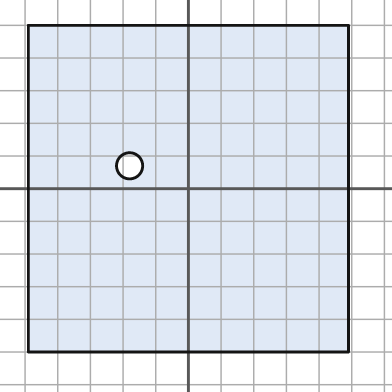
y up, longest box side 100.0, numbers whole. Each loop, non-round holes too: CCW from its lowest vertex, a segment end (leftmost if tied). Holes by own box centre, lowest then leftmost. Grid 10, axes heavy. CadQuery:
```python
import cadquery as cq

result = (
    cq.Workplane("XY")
    .moveTo(-49.0, -50.0)
    .lineTo(49.0, -50.0)
    .lineTo(49.0, 50.0)
    .lineTo(-49.0, 50.0)
    .close()
    .moveTo(-18.0, 7.0)
    .circle(4.0)
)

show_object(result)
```